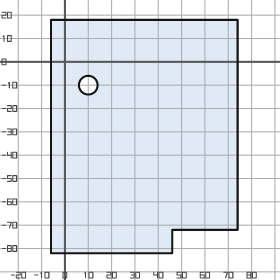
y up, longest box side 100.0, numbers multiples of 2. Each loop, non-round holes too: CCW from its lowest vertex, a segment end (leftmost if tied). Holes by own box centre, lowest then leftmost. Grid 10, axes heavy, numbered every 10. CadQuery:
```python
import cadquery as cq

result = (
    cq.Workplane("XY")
    .moveTo(-6.0, -82.0)
    .lineTo(46.0, -82.0)
    .lineTo(46.0, -72.0)
    .lineTo(74.0, -72.0)
    .lineTo(74.0, 18.0)
    .lineTo(-6.0, 18.0)
    .close()
    .moveTo(10.0, -10.0)
    .circle(4.0)
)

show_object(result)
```